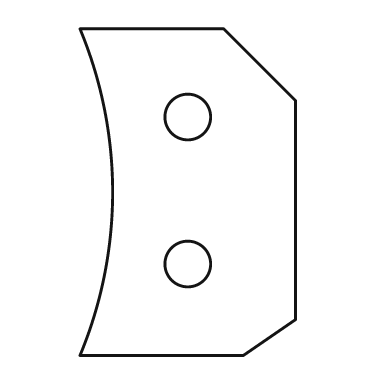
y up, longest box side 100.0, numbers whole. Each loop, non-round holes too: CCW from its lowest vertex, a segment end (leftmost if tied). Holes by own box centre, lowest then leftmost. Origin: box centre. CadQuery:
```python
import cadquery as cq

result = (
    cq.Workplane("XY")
    .moveTo(-33.0, -50.0)
    .lineTo(17.0, -50.0)
    .lineTo(33.0, -39.0)
    .lineTo(33.0, 28.0)
    .lineTo(11.0, 50.0)
    .lineTo(-33.0, 50.0)
    .threePointArc((-23.0, 0.0), (-33.0, -50.0))
    .close()
    .moveTo(0.0, -22.0)
    .circle(7.0)
    .moveTo(0.0, 23.0)
    .circle(7.0)
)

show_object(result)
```